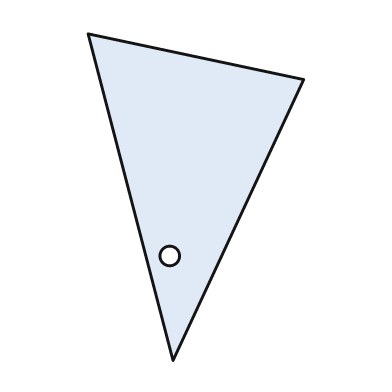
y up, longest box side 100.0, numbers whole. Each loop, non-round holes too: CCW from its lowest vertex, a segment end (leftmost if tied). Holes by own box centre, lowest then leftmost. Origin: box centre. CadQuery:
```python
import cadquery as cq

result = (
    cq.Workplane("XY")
    .moveTo(-7.0, -50.0)
    .lineTo(33.0, 36.0)
    .lineTo(-33.0, 50.0)
    .close()
    .moveTo(-8.0, -18.0)
    .circle(3.0)
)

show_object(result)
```